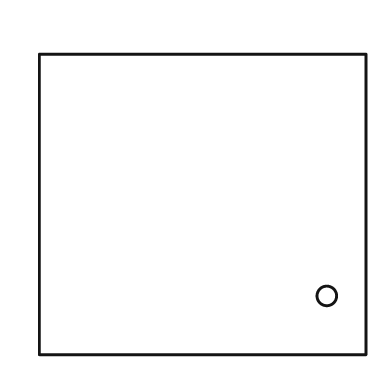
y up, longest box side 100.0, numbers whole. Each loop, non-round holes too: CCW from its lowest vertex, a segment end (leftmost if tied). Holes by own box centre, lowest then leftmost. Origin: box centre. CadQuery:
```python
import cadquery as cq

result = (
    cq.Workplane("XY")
    .moveTo(-50.0, -46.0)
    .lineTo(50.0, -46.0)
    .lineTo(50.0, 46.0)
    .lineTo(-50.0, 46.0)
    .close()
    .moveTo(38.0, -28.0)
    .circle(3.0)
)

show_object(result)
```